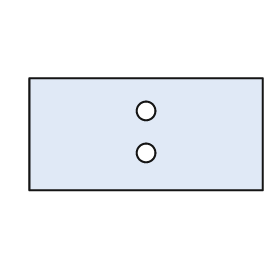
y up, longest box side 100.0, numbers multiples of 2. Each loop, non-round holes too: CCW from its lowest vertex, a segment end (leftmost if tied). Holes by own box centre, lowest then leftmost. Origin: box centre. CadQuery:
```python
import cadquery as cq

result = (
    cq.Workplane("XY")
    .moveTo(-50.0, -24.0)
    .lineTo(50.0, -24.0)
    .lineTo(50.0, 24.0)
    .lineTo(-50.0, 24.0)
    .close()
    .moveTo(0.0, -8.0)
    .circle(4.0)
    .moveTo(0.0, 10.0)
    .circle(4.0)
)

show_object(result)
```